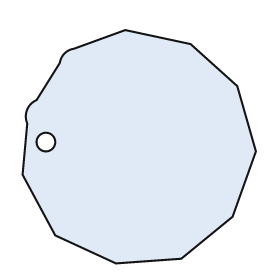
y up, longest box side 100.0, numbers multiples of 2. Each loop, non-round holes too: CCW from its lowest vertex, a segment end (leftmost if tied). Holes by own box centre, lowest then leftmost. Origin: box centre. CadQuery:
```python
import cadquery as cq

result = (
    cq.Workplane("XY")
    .moveTo(-10.0, -50.0)
    .lineTo(18.0, -48.0)
    .lineTo(40.0, -30.0)
    .lineTo(50.0, -2.0)
    .lineTo(42.0, 26.0)
    .lineTo(22.0, 44.0)
    .lineTo(-6.0, 50.0)
    .lineTo(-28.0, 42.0)
    .threePointArc((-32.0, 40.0), (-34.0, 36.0))
    .lineTo(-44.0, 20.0)
    .threePointArc((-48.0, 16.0), (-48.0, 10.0))
    .lineTo(-50.0, -12.0)
    .lineTo(-36.0, -38.0)
    .close()
    .moveTo(-40.0, 2.0)
    .circle(4.0)
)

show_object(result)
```